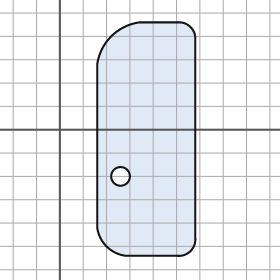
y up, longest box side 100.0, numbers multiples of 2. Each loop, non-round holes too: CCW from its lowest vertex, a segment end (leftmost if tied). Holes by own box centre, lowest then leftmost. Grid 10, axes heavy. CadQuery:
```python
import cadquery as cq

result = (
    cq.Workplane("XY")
    .moveTo(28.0, -54.0)
    .lineTo(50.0, -54.0)
    .threePointArc((56.0, -52.0), (58.0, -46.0))
    .lineTo(58.0, 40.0)
    .threePointArc((56.0, 44.0), (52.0, 46.0))
    .lineTo(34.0, 46.0)
    .threePointArc((22.0, 40.0), (16.0, 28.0))
    .lineTo(16.0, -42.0)
    .threePointArc((20.0, -50.0), (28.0, -54.0))
    .close()
    .moveTo(26.0, -20.0)
    .circle(4.0)
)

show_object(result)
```